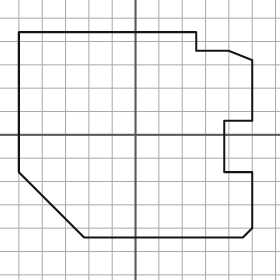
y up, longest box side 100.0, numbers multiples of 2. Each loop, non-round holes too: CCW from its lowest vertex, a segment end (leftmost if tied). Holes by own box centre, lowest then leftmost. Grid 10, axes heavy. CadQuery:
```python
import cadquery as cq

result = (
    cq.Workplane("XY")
    .moveTo(-22.0, -44.0)
    .lineTo(46.0, -44.0)
    .lineTo(50.0, -40.0)
    .lineTo(50.0, -16.0)
    .lineTo(38.0, -16.0)
    .lineTo(38.0, 6.0)
    .lineTo(50.0, 6.0)
    .lineTo(50.0, 32.0)
    .lineTo(40.0, 36.0)
    .lineTo(26.0, 36.0)
    .lineTo(26.0, 44.0)
    .lineTo(-50.0, 44.0)
    .lineTo(-50.0, -16.0)
    .close()
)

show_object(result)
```